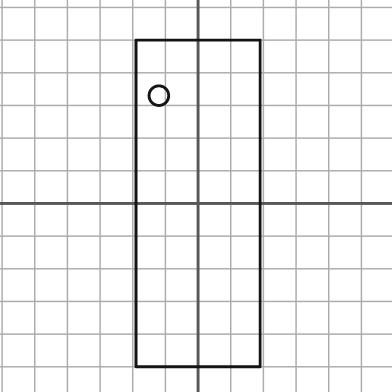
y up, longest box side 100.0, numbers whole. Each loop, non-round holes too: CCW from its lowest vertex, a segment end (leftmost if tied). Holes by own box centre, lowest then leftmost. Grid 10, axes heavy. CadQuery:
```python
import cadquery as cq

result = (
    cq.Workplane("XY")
    .moveTo(-19.0, -50.0)
    .lineTo(19.0, -50.0)
    .lineTo(19.0, 50.0)
    .lineTo(-19.0, 50.0)
    .close()
    .moveTo(-12.0, 33.0)
    .circle(3.0)
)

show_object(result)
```